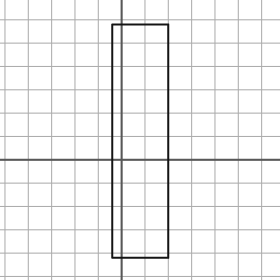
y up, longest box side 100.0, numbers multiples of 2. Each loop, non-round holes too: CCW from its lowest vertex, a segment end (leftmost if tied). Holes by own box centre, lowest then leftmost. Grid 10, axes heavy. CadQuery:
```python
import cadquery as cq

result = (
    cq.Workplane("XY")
    .moveTo(-4.0, -42.0)
    .lineTo(20.0, -42.0)
    .lineTo(20.0, 58.0)
    .lineTo(-4.0, 58.0)
    .close()
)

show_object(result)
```